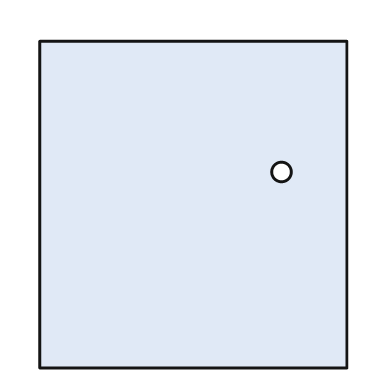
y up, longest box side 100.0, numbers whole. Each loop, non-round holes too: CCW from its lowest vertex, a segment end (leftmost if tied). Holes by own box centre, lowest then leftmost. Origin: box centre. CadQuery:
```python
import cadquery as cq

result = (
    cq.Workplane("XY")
    .moveTo(-47.0, -50.0)
    .lineTo(47.0, -50.0)
    .lineTo(47.0, 50.0)
    .lineTo(-47.0, 50.0)
    .close()
    .moveTo(27.0, 10.0)
    .circle(3.0)
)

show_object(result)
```